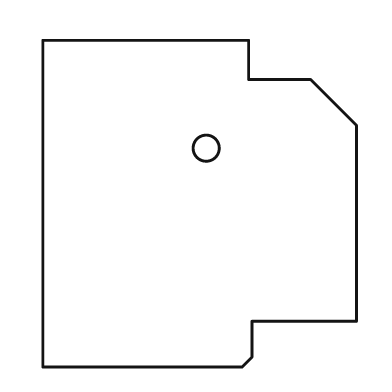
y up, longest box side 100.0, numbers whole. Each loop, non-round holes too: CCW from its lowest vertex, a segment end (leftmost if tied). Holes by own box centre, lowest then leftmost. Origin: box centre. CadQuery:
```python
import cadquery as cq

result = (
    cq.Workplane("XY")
    .moveTo(-48.0, -50.0)
    .lineTo(13.0, -50.0)
    .lineTo(16.0, -47.0)
    .lineTo(16.0, -36.0)
    .lineTo(48.0, -36.0)
    .lineTo(48.0, 24.0)
    .lineTo(34.0, 38.0)
    .lineTo(15.0, 38.0)
    .lineTo(15.0, 50.0)
    .lineTo(-48.0, 50.0)
    .close()
    .moveTo(2.0, 17.0)
    .circle(4.0)
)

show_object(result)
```